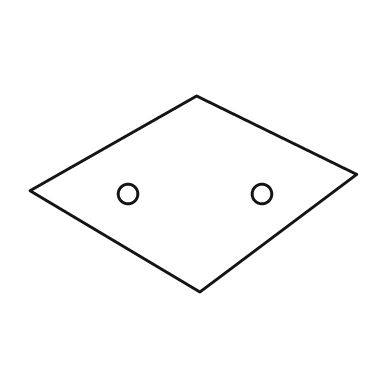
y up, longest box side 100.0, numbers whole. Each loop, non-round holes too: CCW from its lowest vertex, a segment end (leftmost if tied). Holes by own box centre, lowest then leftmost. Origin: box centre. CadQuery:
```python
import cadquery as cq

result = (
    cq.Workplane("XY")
    .moveTo(2.0, -30.0)
    .lineTo(50.0, 6.0)
    .lineTo(1.0, 30.0)
    .lineTo(-50.0, 1.0)
    .close()
    .moveTo(-20.0, 0.0)
    .circle(3.0)
    .moveTo(21.0, 0.0)
    .circle(3.0)
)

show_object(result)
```